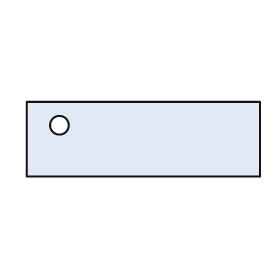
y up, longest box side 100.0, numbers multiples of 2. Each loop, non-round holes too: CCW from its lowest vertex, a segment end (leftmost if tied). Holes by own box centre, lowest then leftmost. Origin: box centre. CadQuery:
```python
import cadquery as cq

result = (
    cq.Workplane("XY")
    .moveTo(-50.0, -16.0)
    .lineTo(50.0, -16.0)
    .lineTo(50.0, 16.0)
    .lineTo(-50.0, 16.0)
    .close()
    .moveTo(-36.0, 6.0)
    .circle(4.0)
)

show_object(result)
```